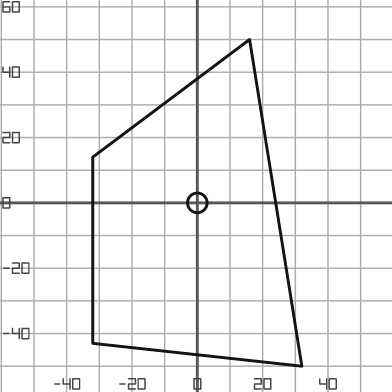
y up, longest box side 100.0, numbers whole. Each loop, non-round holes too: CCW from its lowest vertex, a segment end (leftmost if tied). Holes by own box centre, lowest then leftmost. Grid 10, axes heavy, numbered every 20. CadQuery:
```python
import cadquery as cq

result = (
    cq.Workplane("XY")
    .moveTo(32.0, -50.0)
    .lineTo(16.0, 50.0)
    .lineTo(-32.0, 14.0)
    .lineTo(-32.0, -43.0)
    .close()
    .moveTo(0.0, 0.0)
    .circle(3.0)
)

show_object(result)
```